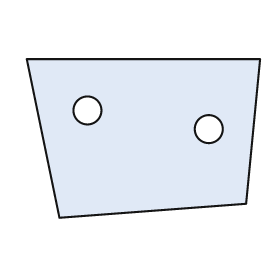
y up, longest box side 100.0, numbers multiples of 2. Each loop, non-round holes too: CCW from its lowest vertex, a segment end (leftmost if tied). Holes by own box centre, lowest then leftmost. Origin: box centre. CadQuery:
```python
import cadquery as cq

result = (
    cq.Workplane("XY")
    .moveTo(-36.0, -34.0)
    .lineTo(44.0, -28.0)
    .lineTo(50.0, 34.0)
    .lineTo(-50.0, 34.0)
    .close()
    .moveTo(28.0, 4.0)
    .circle(6.0)
    .moveTo(-24.0, 12.0)
    .circle(6.0)
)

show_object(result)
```